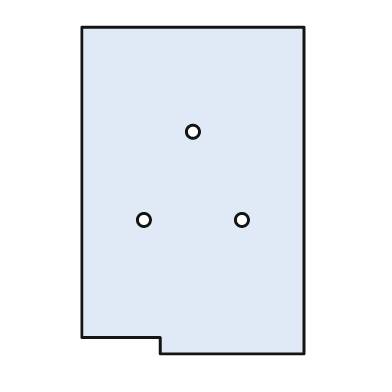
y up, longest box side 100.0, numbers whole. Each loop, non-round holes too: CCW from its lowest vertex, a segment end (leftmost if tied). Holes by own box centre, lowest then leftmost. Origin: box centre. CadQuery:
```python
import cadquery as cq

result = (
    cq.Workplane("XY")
    .moveTo(-10.0, -50.0)
    .lineTo(34.0, -50.0)
    .lineTo(34.0, 50.0)
    .lineTo(-34.0, 50.0)
    .lineTo(-34.0, -45.0)
    .lineTo(-10.0, -45.0)
    .close()
    .moveTo(-15.0, -9.0)
    .circle(2.0)
    .moveTo(15.0, -9.0)
    .circle(2.0)
    .moveTo(0.0, 18.0)
    .circle(2.0)
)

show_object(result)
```